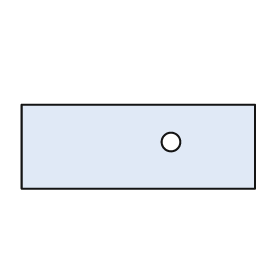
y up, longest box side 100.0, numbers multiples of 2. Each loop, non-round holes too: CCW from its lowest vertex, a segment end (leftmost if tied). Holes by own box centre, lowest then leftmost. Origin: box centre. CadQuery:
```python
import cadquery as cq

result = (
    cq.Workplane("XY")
    .moveTo(-50.0, -18.0)
    .lineTo(50.0, -18.0)
    .lineTo(50.0, 18.0)
    .lineTo(-50.0, 18.0)
    .close()
    .moveTo(14.0, 2.0)
    .circle(4.0)
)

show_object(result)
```